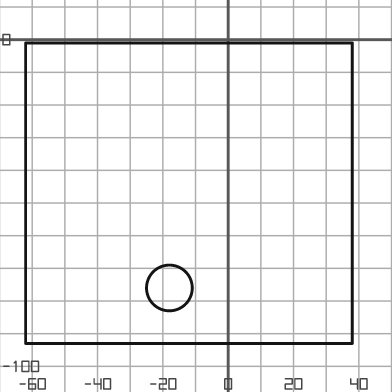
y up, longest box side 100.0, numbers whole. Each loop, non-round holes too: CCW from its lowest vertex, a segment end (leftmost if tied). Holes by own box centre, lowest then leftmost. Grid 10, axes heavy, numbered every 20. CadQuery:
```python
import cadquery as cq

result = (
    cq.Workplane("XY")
    .moveTo(-62.0, -93.0)
    .lineTo(38.0, -93.0)
    .lineTo(38.0, -1.0)
    .lineTo(-62.0, -1.0)
    .close()
    .moveTo(-18.0, -76.0)
    .circle(7.0)
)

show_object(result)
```